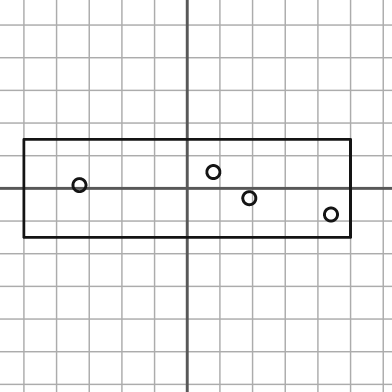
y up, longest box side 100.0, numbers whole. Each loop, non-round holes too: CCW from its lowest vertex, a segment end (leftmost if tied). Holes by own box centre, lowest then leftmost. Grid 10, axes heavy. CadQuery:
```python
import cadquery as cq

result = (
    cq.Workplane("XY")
    .moveTo(-50.0, -15.0)
    .lineTo(50.0, -15.0)
    .lineTo(50.0, 15.0)
    .lineTo(-50.0, 15.0)
    .close()
    .moveTo(44.0, -8.0)
    .circle(2.0)
    .moveTo(19.0, -3.0)
    .circle(2.0)
    .moveTo(-33.0, 1.0)
    .circle(2.0)
    .moveTo(8.0, 5.0)
    .circle(2.0)
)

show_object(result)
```